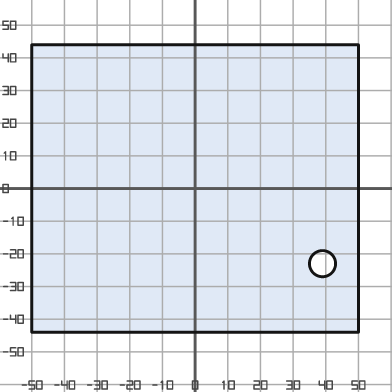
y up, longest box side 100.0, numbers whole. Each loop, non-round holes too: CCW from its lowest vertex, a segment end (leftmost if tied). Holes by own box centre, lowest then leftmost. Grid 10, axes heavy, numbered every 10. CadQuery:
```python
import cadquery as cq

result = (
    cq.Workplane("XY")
    .moveTo(-50.0, -44.0)
    .lineTo(50.0, -44.0)
    .lineTo(50.0, 44.0)
    .lineTo(-50.0, 44.0)
    .close()
    .moveTo(39.0, -23.0)
    .circle(4.0)
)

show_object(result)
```